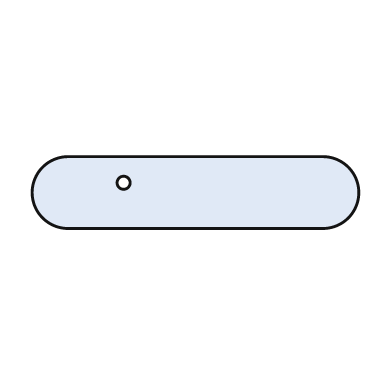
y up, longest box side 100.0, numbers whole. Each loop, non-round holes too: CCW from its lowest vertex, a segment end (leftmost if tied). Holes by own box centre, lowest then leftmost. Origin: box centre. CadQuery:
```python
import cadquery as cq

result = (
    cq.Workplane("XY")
    .moveTo(-39.0, -11.0)
    .lineTo(39.0, -11.0)
    .threePointArc((50.0, 0.0), (39.0, 11.0))
    .lineTo(-39.0, 11.0)
    .threePointArc((-50.0, 0.0), (-39.0, -11.0))
    .close()
    .moveTo(-22.0, 3.0)
    .circle(2.0)
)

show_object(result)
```